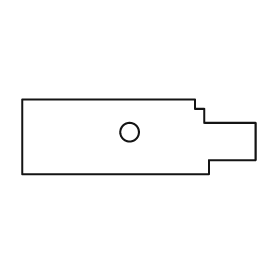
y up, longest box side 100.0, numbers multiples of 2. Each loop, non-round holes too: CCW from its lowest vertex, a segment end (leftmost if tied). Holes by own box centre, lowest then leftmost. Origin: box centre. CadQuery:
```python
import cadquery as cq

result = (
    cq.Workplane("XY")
    .moveTo(-50.0, -16.0)
    .lineTo(30.0, -16.0)
    .lineTo(30.0, -10.0)
    .lineTo(50.0, -10.0)
    .lineTo(50.0, 6.0)
    .lineTo(28.0, 6.0)
    .lineTo(28.0, 12.0)
    .lineTo(24.0, 12.0)
    .lineTo(24.0, 16.0)
    .lineTo(-50.0, 16.0)
    .close()
    .moveTo(-4.0, 2.0)
    .circle(4.0)
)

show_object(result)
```